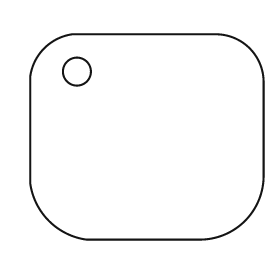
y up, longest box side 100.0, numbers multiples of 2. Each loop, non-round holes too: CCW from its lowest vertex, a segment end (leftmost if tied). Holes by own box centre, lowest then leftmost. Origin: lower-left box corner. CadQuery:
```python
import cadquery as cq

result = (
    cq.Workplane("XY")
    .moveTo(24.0, 0.0)
    .lineTo(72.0, 0.0)
    .threePointArc((92.0, 8.0), (100.0, 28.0))
    .lineTo(100.0, 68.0)
    .threePointArc((94.0, 82.0), (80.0, 88.0))
    .lineTo(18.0, 88.0)
    .threePointArc((6.0, 82.0), (0.0, 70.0))
    .lineTo(0.0, 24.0)
    .threePointArc((8.0, 8.0), (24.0, 0.0))
    .close()
    .moveTo(20.0, 72.0)
    .circle(6.0)
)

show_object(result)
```